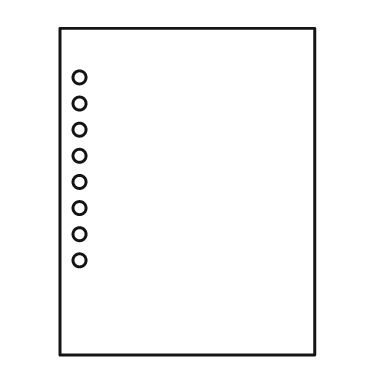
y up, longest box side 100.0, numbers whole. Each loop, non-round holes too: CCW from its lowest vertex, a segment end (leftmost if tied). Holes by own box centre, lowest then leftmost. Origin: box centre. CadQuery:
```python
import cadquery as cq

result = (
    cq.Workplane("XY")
    .moveTo(-39.0, -50.0)
    .lineTo(39.0, -50.0)
    .lineTo(39.0, 50.0)
    .lineTo(-39.0, 50.0)
    .close()
    .moveTo(-33.0, -21.0)
    .circle(2.0)
    .moveTo(-33.0, -13.0)
    .circle(2.0)
    .moveTo(-33.0, -5.0)
    .circle(2.0)
    .moveTo(-33.0, 3.0)
    .circle(2.0)
    .moveTo(-33.0, 11.0)
    .circle(2.0)
    .moveTo(-33.0, 19.0)
    .circle(2.0)
    .moveTo(-33.0, 27.0)
    .circle(2.0)
    .moveTo(-33.0, 35.0)
    .circle(2.0)
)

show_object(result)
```